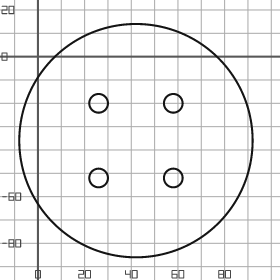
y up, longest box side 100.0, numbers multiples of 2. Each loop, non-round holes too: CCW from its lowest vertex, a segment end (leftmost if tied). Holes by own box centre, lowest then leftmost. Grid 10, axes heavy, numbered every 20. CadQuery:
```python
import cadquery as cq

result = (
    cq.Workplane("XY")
    .moveTo(42.0, -36.0)
    .circle(50.0)
    .moveTo(26.0, -52.0)
    .circle(4.0)
    .moveTo(58.0, -52.0)
    .circle(4.0)
    .moveTo(26.0, -20.0)
    .circle(4.0)
    .moveTo(58.0, -20.0)
    .circle(4.0)
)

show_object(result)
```